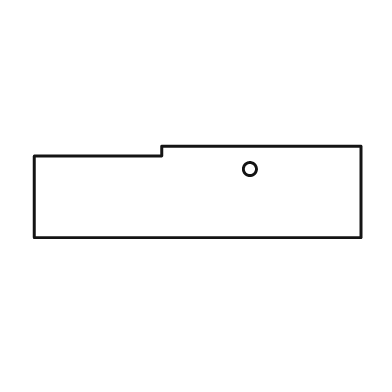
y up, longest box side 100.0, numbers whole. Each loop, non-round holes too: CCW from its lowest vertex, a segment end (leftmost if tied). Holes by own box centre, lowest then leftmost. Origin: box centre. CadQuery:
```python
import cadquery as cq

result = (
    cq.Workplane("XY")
    .moveTo(-50.0, -14.0)
    .lineTo(50.0, -14.0)
    .lineTo(50.0, 14.0)
    .lineTo(-11.0, 14.0)
    .lineTo(-11.0, 11.0)
    .lineTo(-50.0, 11.0)
    .close()
    .moveTo(16.0, 7.0)
    .circle(2.0)
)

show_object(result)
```